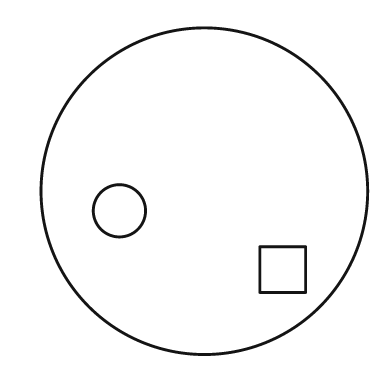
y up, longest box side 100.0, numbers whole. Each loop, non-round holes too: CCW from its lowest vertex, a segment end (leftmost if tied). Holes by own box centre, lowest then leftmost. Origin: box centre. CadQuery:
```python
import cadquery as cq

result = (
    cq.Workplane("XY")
    .moveTo(0.0, 0.0)
    .circle(50.0)
    .moveTo(17.0, -31.0)
    .lineTo(31.0, -31.0)
    .lineTo(31.0, -17.0)
    .lineTo(17.0, -17.0)
    .close()
    .moveTo(-26.0, -6.0)
    .circle(8.0)
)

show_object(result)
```